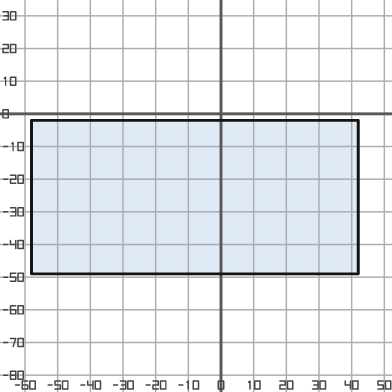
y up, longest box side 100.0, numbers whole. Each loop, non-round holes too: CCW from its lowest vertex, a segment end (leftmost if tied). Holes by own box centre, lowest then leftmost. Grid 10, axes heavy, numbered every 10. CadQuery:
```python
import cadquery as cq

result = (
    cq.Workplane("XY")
    .moveTo(-58.0, -49.0)
    .lineTo(42.0, -49.0)
    .lineTo(42.0, -2.0)
    .lineTo(-58.0, -2.0)
    .close()
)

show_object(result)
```